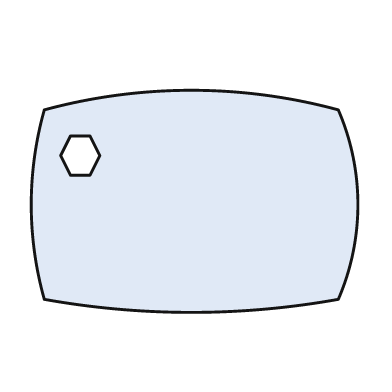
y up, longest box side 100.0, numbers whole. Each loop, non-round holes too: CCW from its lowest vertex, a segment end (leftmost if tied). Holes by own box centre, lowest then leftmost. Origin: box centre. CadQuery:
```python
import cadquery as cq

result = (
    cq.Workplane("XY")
    .moveTo(-46.0, -30.0)
    .threePointArc((-1.0, -34.0), (44.0, -30.0))
    .threePointArc((50.0, -1.0), (44.0, 28.0))
    .threePointArc((-1.0, 34.0), (-46.0, 28.0))
    .threePointArc((-50.0, -1.0), (-46.0, -30.0))
    .close()
    .moveTo(-38.0, 8.0)
    .lineTo(-32.0, 8.0)
    .lineTo(-29.0, 14.0)
    .lineTo(-32.0, 20.0)
    .lineTo(-38.0, 20.0)
    .lineTo(-41.0, 14.0)
    .close()
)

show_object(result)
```